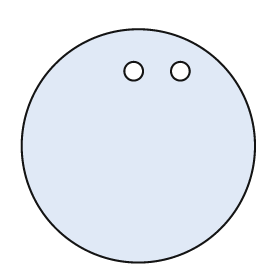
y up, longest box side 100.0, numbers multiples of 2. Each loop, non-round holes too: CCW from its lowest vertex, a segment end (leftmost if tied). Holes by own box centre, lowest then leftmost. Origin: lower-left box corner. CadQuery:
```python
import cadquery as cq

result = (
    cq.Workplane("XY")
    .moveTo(50.0, 50.0)
    .circle(50.0)
    .moveTo(48.0, 82.0)
    .circle(4.0)
    .moveTo(68.0, 82.0)
    .circle(4.0)
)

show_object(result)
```